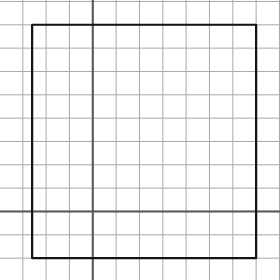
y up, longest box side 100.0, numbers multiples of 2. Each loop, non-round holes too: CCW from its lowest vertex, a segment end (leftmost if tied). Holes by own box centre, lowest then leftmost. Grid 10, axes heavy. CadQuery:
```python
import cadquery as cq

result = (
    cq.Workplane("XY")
    .moveTo(-26.0, -20.0)
    .lineTo(70.0, -20.0)
    .lineTo(70.0, 80.0)
    .lineTo(-26.0, 80.0)
    .close()
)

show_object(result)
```